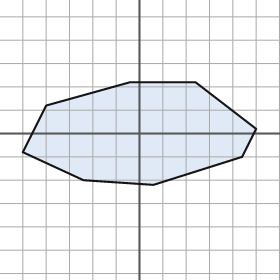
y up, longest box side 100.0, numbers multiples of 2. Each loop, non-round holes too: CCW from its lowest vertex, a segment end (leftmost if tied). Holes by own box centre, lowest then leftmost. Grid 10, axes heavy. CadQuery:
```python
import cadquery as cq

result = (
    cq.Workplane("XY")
    .moveTo(6.0, -22.0)
    .lineTo(44.0, -10.0)
    .lineTo(50.0, 2.0)
    .lineTo(24.0, 22.0)
    .lineTo(-4.0, 22.0)
    .lineTo(-40.0, 12.0)
    .lineTo(-50.0, -8.0)
    .lineTo(-24.0, -20.0)
    .close()
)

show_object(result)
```